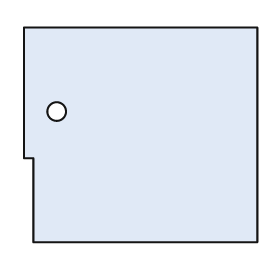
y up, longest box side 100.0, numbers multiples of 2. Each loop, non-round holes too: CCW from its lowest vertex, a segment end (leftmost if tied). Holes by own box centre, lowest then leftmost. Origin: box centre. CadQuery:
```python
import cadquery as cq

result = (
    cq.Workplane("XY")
    .moveTo(-46.0, -46.0)
    .lineTo(50.0, -46.0)
    .lineTo(50.0, 46.0)
    .lineTo(-50.0, 46.0)
    .lineTo(-50.0, -10.0)
    .lineTo(-46.0, -10.0)
    .close()
    .moveTo(-36.0, 10.0)
    .circle(4.0)
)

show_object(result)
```